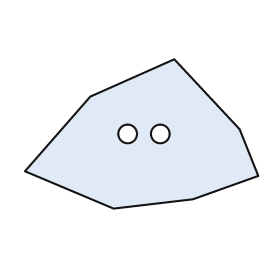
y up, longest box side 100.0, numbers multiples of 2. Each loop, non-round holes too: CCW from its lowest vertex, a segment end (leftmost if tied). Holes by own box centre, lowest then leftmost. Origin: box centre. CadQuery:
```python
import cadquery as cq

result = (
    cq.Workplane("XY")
    .moveTo(-12.0, -32.0)
    .lineTo(22.0, -28.0)
    .lineTo(50.0, -18.0)
    .lineTo(42.0, 2.0)
    .lineTo(14.0, 32.0)
    .lineTo(-22.0, 16.0)
    .lineTo(-50.0, -16.0)
    .close()
    .moveTo(-6.0, 0.0)
    .circle(4.0)
    .moveTo(8.0, 0.0)
    .circle(4.0)
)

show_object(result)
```